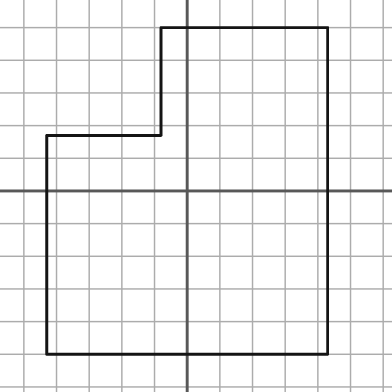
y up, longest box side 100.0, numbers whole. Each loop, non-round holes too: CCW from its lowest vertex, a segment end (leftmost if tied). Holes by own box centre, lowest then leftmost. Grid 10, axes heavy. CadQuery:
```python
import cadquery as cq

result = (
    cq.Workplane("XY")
    .moveTo(-43.0, -50.0)
    .lineTo(43.0, -50.0)
    .lineTo(43.0, 50.0)
    .lineTo(-8.0, 50.0)
    .lineTo(-8.0, 17.0)
    .lineTo(-43.0, 17.0)
    .close()
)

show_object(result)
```